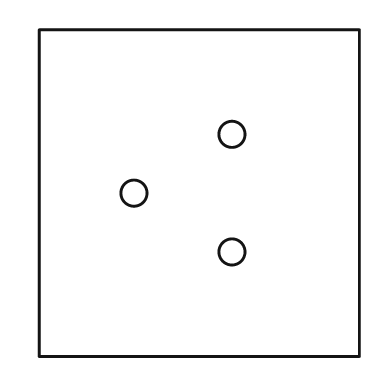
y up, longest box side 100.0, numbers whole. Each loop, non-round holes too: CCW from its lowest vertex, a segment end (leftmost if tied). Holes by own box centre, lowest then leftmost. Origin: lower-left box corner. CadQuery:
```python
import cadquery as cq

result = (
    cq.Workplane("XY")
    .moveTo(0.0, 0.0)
    .lineTo(98.0, 0.0)
    .lineTo(98.0, 100.0)
    .lineTo(0.0, 100.0)
    .close()
    .moveTo(59.0, 32.0)
    .circle(4.0)
    .moveTo(29.0, 50.0)
    .circle(4.0)
    .moveTo(59.0, 68.0)
    .circle(4.0)
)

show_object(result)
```